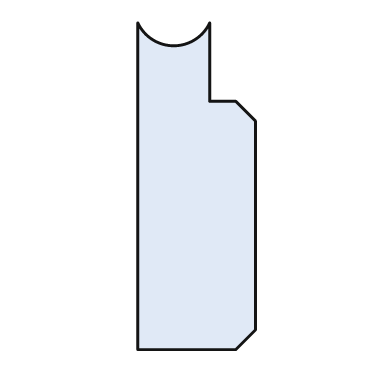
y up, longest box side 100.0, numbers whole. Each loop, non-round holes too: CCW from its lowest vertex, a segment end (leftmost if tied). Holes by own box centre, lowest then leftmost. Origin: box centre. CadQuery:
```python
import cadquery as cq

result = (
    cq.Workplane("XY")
    .moveTo(-18.0, -50.0)
    .lineTo(12.0, -50.0)
    .lineTo(18.0, -44.0)
    .lineTo(18.0, 20.0)
    .lineTo(12.0, 26.0)
    .lineTo(4.0, 26.0)
    .lineTo(4.0, 50.0)
    .threePointArc((-7.0, 43.0), (-18.0, 50.0))
    .close()
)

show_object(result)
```